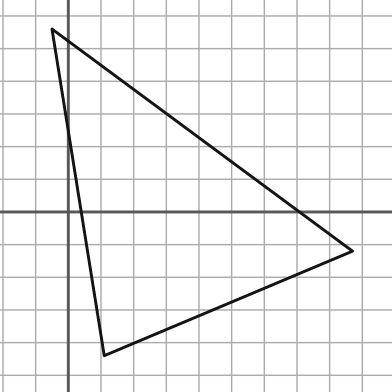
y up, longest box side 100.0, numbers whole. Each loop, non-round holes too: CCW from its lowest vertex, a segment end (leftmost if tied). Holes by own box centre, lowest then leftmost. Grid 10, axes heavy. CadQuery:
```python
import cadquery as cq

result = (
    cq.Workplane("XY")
    .moveTo(11.0, -44.0)
    .lineTo(87.0, -12.0)
    .lineTo(-5.0, 56.0)
    .close()
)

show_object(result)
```